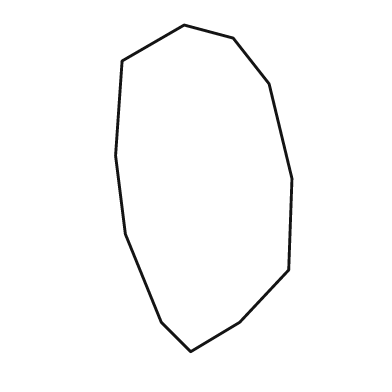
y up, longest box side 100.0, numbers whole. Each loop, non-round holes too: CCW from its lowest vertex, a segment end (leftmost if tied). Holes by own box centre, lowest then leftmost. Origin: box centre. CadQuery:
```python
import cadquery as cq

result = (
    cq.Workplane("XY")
    .moveTo(-4.0, -50.0)
    .lineTo(11.0, -41.0)
    .lineTo(26.0, -25.0)
    .lineTo(27.0, 3.0)
    .lineTo(20.0, 32.0)
    .lineTo(9.0, 46.0)
    .lineTo(-6.0, 50.0)
    .lineTo(-25.0, 39.0)
    .lineTo(-27.0, 10.0)
    .lineTo(-24.0, -14.0)
    .lineTo(-13.0, -41.0)
    .close()
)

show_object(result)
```